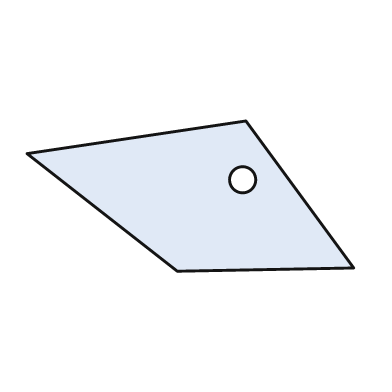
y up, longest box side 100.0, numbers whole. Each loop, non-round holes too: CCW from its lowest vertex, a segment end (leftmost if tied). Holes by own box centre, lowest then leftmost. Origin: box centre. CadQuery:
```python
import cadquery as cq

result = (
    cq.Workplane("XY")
    .moveTo(-4.0, -23.0)
    .lineTo(50.0, -22.0)
    .lineTo(17.0, 23.0)
    .lineTo(-50.0, 13.0)
    .close()
    .moveTo(16.0, 5.0)
    .circle(4.0)
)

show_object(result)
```